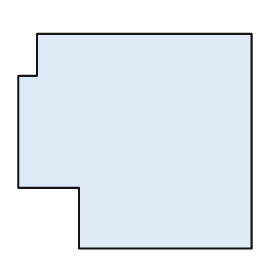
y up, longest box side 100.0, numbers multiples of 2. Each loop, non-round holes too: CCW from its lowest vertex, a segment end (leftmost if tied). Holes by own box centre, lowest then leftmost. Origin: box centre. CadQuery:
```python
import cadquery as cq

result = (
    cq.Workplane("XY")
    .moveTo(-24.0, -46.0)
    .lineTo(50.0, -46.0)
    .lineTo(50.0, 46.0)
    .lineTo(-42.0, 46.0)
    .lineTo(-42.0, 28.0)
    .lineTo(-50.0, 28.0)
    .lineTo(-50.0, -20.0)
    .lineTo(-24.0, -20.0)
    .close()
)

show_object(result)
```